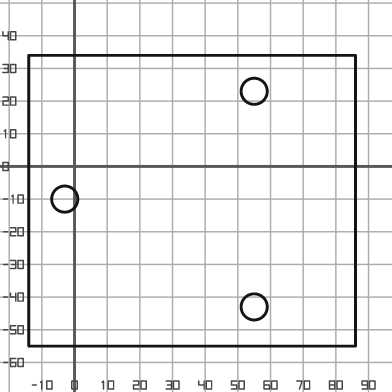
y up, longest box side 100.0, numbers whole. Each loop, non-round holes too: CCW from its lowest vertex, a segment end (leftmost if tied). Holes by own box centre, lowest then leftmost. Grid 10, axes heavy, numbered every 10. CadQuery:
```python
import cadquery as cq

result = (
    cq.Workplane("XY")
    .moveTo(-14.0, -55.0)
    .lineTo(86.0, -55.0)
    .lineTo(86.0, 34.0)
    .lineTo(-14.0, 34.0)
    .close()
    .moveTo(55.0, -43.0)
    .circle(4.0)
    .moveTo(-3.0, -10.0)
    .circle(4.0)
    .moveTo(55.0, 23.0)
    .circle(4.0)
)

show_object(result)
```